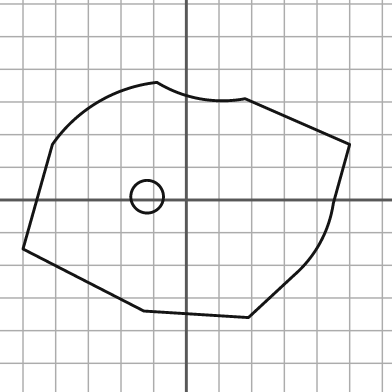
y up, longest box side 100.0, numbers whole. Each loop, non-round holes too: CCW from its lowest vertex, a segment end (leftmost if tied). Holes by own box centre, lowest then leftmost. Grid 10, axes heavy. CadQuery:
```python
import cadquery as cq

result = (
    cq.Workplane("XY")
    .moveTo(19.0, -36.0)
    .lineTo(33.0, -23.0)
    .threePointArc((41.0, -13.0), (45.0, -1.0))
    .lineTo(50.0, 17.0)
    .lineTo(18.0, 31.0)
    .threePointArc((4.0, 31.0), (-9.0, 36.0))
    .threePointArc((-27.0, 30.0), (-41.0, 17.0))
    .lineTo(-50.0, -15.0)
    .lineTo(-13.0, -34.0)
    .close()
    .moveTo(-12.0, 1.0)
    .circle(5.0)
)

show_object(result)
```